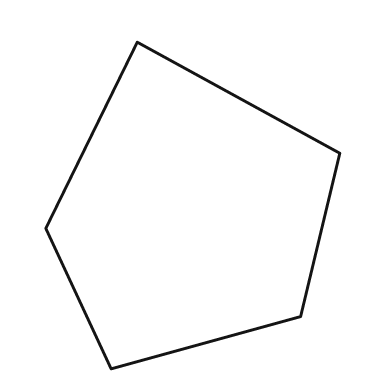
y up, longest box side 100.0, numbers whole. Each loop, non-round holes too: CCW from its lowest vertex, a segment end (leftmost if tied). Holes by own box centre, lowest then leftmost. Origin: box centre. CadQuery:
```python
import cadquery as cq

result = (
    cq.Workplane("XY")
    .moveTo(-25.0, -50.0)
    .lineTo(33.0, -34.0)
    .lineTo(45.0, 16.0)
    .lineTo(-17.0, 50.0)
    .lineTo(-45.0, -7.0)
    .close()
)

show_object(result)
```